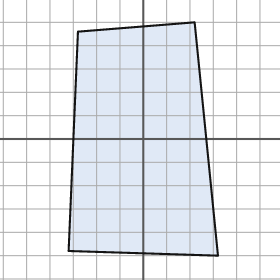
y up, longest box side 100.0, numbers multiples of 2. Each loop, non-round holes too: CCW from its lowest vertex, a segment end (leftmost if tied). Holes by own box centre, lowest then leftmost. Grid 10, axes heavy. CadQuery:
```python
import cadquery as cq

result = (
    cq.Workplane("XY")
    .moveTo(32.0, -50.0)
    .lineTo(22.0, 50.0)
    .lineTo(-28.0, 46.0)
    .lineTo(-32.0, -48.0)
    .close()
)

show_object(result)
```